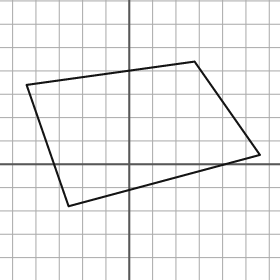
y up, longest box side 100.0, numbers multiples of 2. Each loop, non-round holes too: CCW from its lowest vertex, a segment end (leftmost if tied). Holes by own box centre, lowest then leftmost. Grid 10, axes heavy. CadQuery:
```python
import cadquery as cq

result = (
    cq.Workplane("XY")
    .moveTo(-26.0, -18.0)
    .lineTo(56.0, 4.0)
    .lineTo(28.0, 44.0)
    .lineTo(-44.0, 34.0)
    .close()
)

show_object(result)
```